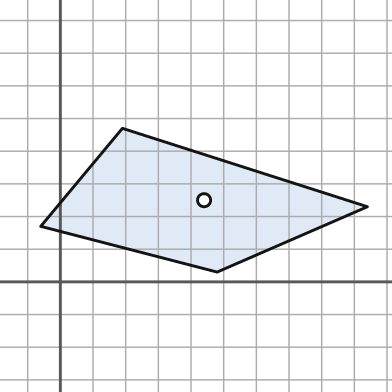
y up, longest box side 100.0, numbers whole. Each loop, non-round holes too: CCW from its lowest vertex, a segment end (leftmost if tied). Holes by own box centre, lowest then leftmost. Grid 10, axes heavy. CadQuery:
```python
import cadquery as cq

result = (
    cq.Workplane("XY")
    .moveTo(48.0, 3.0)
    .lineTo(94.0, 23.0)
    .lineTo(19.0, 47.0)
    .lineTo(-6.0, 17.0)
    .close()
    .moveTo(44.0, 25.0)
    .circle(2.0)
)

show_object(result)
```